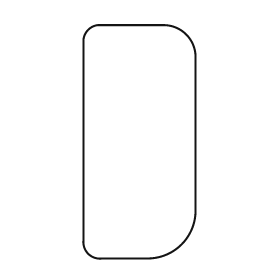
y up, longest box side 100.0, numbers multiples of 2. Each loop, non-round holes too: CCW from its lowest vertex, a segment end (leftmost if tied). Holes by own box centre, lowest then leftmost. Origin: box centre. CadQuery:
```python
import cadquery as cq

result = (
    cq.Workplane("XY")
    .moveTo(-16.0, -50.0)
    .lineTo(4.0, -50.0)
    .threePointArc((18.0, -44.0), (24.0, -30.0))
    .lineTo(24.0, 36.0)
    .threePointArc((20.0, 46.0), (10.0, 50.0))
    .lineTo(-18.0, 50.0)
    .threePointArc((-22.0, 48.0), (-24.0, 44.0))
    .lineTo(-24.0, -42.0)
    .threePointArc((-22.0, -48.0), (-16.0, -50.0))
    .close()
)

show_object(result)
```